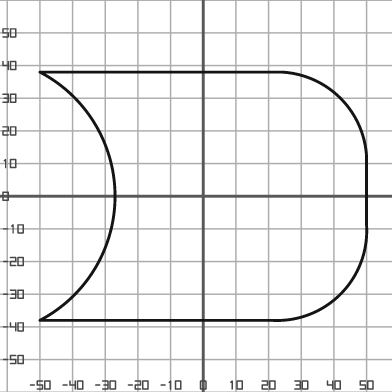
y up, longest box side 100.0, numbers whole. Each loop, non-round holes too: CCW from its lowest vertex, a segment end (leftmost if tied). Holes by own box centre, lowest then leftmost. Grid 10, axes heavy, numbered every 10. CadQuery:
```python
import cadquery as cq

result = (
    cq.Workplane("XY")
    .moveTo(-50.0, -38.0)
    .lineTo(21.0, -38.0)
    .threePointArc((42.0, -30.0), (50.0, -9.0))
    .lineTo(50.0, 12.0)
    .threePointArc((42.0, 30.0), (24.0, 38.0))
    .lineTo(-50.0, 38.0)
    .threePointArc((-27.0, 0.0), (-50.0, -38.0))
    .close()
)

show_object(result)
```